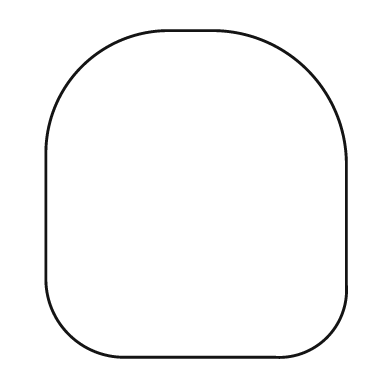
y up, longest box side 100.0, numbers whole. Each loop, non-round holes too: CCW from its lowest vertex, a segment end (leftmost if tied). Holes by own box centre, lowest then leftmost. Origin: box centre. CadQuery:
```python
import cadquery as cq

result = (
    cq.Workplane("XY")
    .moveTo(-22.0, -50.0)
    .lineTo(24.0, -50.0)
    .threePointArc((40.0, -44.0), (46.0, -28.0))
    .lineTo(46.0, 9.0)
    .threePointArc((34.0, 38.0), (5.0, 50.0))
    .lineTo(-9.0, 50.0)
    .threePointArc((-35.0, 39.0), (-46.0, 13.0))
    .lineTo(-46.0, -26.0)
    .threePointArc((-39.0, -43.0), (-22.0, -50.0))
    .close()
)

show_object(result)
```